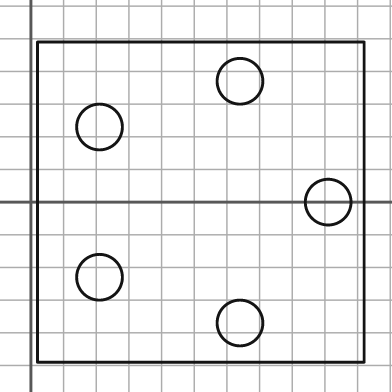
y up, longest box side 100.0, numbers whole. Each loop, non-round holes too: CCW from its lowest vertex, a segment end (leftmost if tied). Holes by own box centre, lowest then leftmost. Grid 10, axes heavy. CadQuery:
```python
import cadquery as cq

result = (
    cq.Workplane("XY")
    .moveTo(2.0, -49.0)
    .lineTo(102.0, -49.0)
    .lineTo(102.0, 49.0)
    .lineTo(2.0, 49.0)
    .close()
    .moveTo(64.0, -37.0)
    .circle(7.0)
    .moveTo(21.0, -23.0)
    .circle(7.0)
    .moveTo(91.0, 0.0)
    .circle(7.0)
    .moveTo(21.0, 23.0)
    .circle(7.0)
    .moveTo(64.0, 37.0)
    .circle(7.0)
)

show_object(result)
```